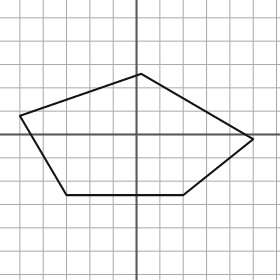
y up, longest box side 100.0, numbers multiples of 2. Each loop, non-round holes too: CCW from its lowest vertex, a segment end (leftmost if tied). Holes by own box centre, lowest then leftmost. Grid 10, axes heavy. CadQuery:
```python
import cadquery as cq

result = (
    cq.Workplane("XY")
    .moveTo(-30.0, -26.0)
    .lineTo(20.0, -26.0)
    .lineTo(50.0, -2.0)
    .lineTo(2.0, 26.0)
    .lineTo(-50.0, 8.0)
    .close()
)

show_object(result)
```